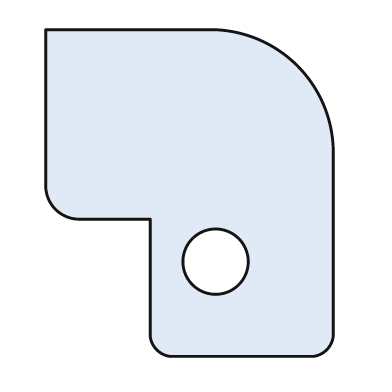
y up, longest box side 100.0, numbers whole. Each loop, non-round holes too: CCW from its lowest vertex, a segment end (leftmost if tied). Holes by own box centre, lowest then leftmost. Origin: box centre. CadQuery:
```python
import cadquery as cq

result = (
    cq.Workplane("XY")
    .moveTo(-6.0, -50.0)
    .lineTo(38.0, -50.0)
    .threePointArc((42.0, -48.0), (44.0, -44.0))
    .lineTo(44.0, 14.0)
    .threePointArc((33.0, 39.0), (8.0, 50.0))
    .lineTo(-44.0, 50.0)
    .lineTo(-44.0, 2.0)
    .threePointArc((-41.0, -5.0), (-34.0, -8.0))
    .lineTo(-12.0, -8.0)
    .lineTo(-12.0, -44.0)
    .threePointArc((-10.0, -48.0), (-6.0, -50.0))
    .close()
    .moveTo(8.0, -21.0)
    .circle(10.0)
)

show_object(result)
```